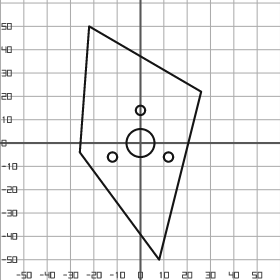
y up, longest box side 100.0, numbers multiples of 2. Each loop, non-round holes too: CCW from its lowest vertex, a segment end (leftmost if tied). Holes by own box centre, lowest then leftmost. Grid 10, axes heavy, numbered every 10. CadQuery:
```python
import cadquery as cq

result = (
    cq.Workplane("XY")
    .moveTo(8.0, -50.0)
    .lineTo(26.0, 22.0)
    .lineTo(-22.0, 50.0)
    .lineTo(-26.0, -4.0)
    .close()
    .moveTo(-12.0, -6.0)
    .circle(2.0)
    .moveTo(12.0, -6.0)
    .circle(2.0)
    .moveTo(0.0, 0.0)
    .circle(6.0)
    .moveTo(0.0, 14.0)
    .circle(2.0)
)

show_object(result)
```